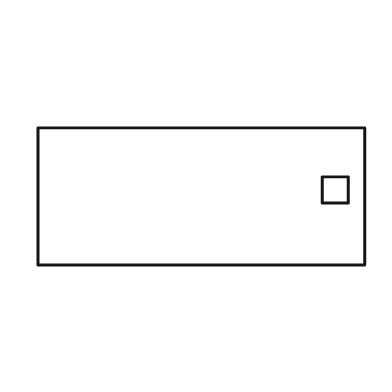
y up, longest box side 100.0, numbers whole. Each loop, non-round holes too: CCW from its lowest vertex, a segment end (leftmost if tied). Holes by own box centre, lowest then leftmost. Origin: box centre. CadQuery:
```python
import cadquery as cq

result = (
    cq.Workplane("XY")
    .moveTo(-50.0, -21.0)
    .lineTo(50.0, -21.0)
    .lineTo(50.0, 21.0)
    .lineTo(-50.0, 21.0)
    .close()
    .moveTo(37.0, -2.0)
    .lineTo(45.0, -2.0)
    .lineTo(45.0, 6.0)
    .lineTo(37.0, 6.0)
    .close()
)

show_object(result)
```